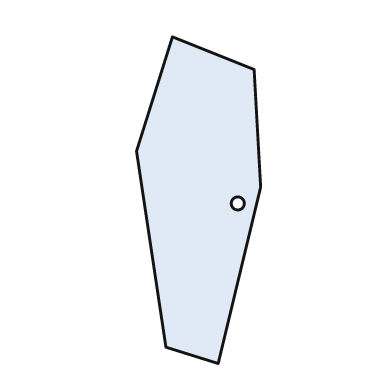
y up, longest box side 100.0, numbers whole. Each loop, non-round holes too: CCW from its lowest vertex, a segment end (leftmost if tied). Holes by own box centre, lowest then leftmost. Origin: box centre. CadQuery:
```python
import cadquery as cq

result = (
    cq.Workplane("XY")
    .moveTo(6.0, -50.0)
    .lineTo(19.0, 4.0)
    .lineTo(17.0, 40.0)
    .lineTo(-8.0, 50.0)
    .lineTo(-19.0, 15.0)
    .lineTo(-10.0, -45.0)
    .close()
    .moveTo(12.0, -1.0)
    .circle(2.0)
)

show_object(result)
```